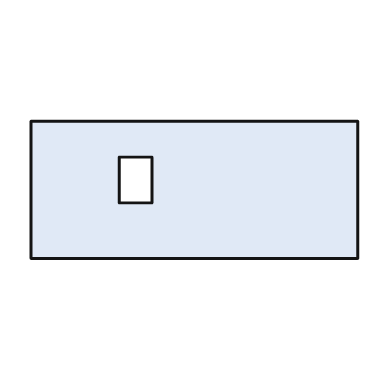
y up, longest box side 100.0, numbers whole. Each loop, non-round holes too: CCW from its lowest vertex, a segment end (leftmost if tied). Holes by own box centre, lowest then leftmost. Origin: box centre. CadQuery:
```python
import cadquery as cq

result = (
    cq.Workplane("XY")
    .moveTo(-50.0, -21.0)
    .lineTo(50.0, -21.0)
    .lineTo(50.0, 21.0)
    .lineTo(-50.0, 21.0)
    .close()
    .moveTo(-23.0, -4.0)
    .lineTo(-13.0, -4.0)
    .lineTo(-13.0, 10.0)
    .lineTo(-23.0, 10.0)
    .close()
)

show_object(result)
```